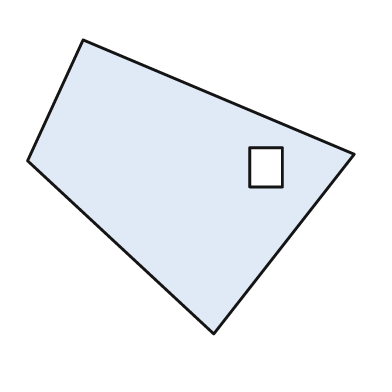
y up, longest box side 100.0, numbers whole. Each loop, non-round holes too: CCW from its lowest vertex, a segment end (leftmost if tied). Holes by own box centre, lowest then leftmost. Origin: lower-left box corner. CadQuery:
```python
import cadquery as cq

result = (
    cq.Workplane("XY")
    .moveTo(57.0, 0.0)
    .lineTo(100.0, 55.0)
    .lineTo(17.0, 90.0)
    .lineTo(0.0, 53.0)
    .close()
    .moveTo(68.0, 45.0)
    .lineTo(78.0, 45.0)
    .lineTo(78.0, 57.0)
    .lineTo(68.0, 57.0)
    .close()
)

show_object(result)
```